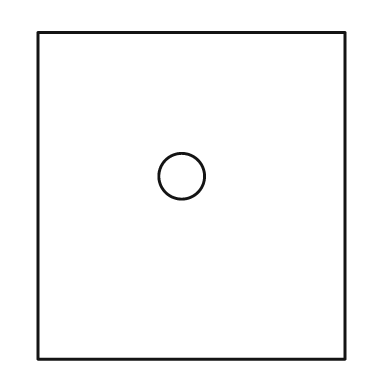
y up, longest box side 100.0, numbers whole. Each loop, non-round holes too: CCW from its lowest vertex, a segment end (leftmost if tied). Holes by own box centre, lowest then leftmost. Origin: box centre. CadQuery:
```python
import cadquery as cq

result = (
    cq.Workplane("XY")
    .moveTo(-47.0, -50.0)
    .lineTo(47.0, -50.0)
    .lineTo(47.0, 50.0)
    .lineTo(-47.0, 50.0)
    .close()
    .moveTo(-3.0, 6.0)
    .circle(7.0)
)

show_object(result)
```